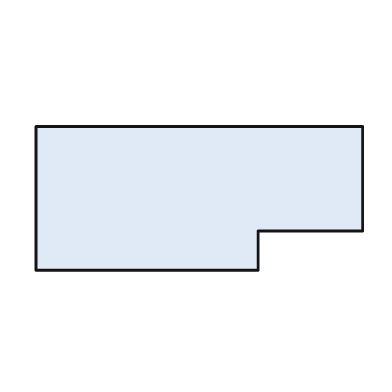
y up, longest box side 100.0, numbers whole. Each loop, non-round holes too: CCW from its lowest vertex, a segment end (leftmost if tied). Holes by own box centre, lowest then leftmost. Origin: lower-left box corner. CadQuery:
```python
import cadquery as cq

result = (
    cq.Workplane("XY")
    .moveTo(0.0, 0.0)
    .lineTo(68.0, 0.0)
    .lineTo(68.0, 12.0)
    .lineTo(100.0, 12.0)
    .lineTo(100.0, 44.0)
    .lineTo(0.0, 44.0)
    .close()
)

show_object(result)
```